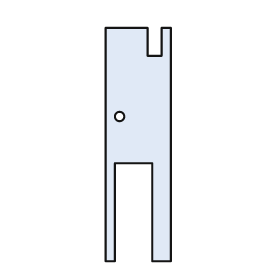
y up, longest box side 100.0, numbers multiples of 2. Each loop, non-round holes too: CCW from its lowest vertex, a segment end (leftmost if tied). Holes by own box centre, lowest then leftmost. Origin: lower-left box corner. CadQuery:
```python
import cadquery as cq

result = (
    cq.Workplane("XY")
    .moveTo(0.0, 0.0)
    .lineTo(4.0, 0.0)
    .lineTo(4.0, 42.0)
    .lineTo(20.0, 42.0)
    .lineTo(20.0, 0.0)
    .lineTo(28.0, 0.0)
    .lineTo(28.0, 100.0)
    .lineTo(24.0, 100.0)
    .lineTo(24.0, 88.0)
    .lineTo(18.0, 88.0)
    .lineTo(18.0, 100.0)
    .lineTo(0.0, 100.0)
    .close()
    .moveTo(6.0, 62.0)
    .circle(2.0)
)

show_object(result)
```